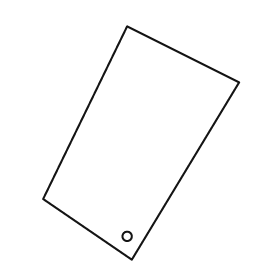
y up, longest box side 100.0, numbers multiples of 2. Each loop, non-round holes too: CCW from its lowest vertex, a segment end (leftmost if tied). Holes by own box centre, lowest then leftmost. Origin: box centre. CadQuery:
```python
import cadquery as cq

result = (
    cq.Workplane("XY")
    .moveTo(-4.0, -50.0)
    .lineTo(42.0, 26.0)
    .lineTo(-6.0, 50.0)
    .lineTo(-42.0, -24.0)
    .close()
    .moveTo(-6.0, -40.0)
    .circle(2.0)
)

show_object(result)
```